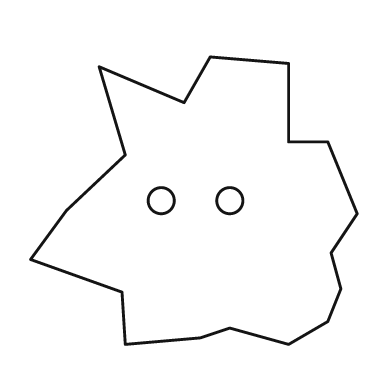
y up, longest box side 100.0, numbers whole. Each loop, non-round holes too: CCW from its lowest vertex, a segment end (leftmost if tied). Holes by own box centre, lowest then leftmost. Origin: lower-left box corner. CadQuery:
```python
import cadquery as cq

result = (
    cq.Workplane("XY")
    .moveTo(29.0, 0.0)
    .lineTo(52.0, 2.0)
    .lineTo(61.0, 5.0)
    .lineTo(79.0, 0.0)
    .lineTo(91.0, 7.0)
    .lineTo(95.0, 17.0)
    .lineTo(92.0, 28.0)
    .lineTo(100.0, 40.0)
    .lineTo(91.0, 62.0)
    .lineTo(79.0, 62.0)
    .lineTo(79.0, 86.0)
    .lineTo(55.0, 88.0)
    .lineTo(47.0, 74.0)
    .lineTo(21.0, 85.0)
    .lineTo(29.0, 58.0)
    .lineTo(11.0, 41.0)
    .lineTo(0.0, 26.0)
    .lineTo(28.0, 16.0)
    .close()
    .moveTo(40.0, 44.0)
    .circle(4.0)
    .moveTo(61.0, 44.0)
    .circle(4.0)
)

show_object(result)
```